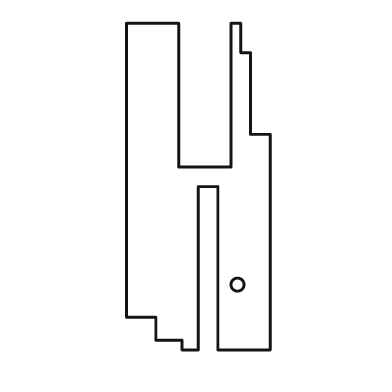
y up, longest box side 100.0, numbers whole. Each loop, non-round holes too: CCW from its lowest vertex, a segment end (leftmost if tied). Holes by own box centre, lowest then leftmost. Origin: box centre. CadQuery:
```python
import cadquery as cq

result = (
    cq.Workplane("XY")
    .moveTo(-5.0, -50.0)
    .lineTo(0.0, -50.0)
    .lineTo(0.0, 0.0)
    .lineTo(6.0, 0.0)
    .lineTo(6.0, -50.0)
    .lineTo(22.0, -50.0)
    .lineTo(22.0, 16.0)
    .lineTo(16.0, 16.0)
    .lineTo(16.0, 41.0)
    .lineTo(13.0, 41.0)
    .lineTo(13.0, 50.0)
    .lineTo(10.0, 50.0)
    .lineTo(10.0, 6.0)
    .lineTo(-6.0, 6.0)
    .lineTo(-6.0, 50.0)
    .lineTo(-22.0, 50.0)
    .lineTo(-22.0, -40.0)
    .lineTo(-13.0, -40.0)
    .lineTo(-13.0, -47.0)
    .lineTo(-5.0, -47.0)
    .close()
    .moveTo(12.0, -30.0)
    .circle(2.0)
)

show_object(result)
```